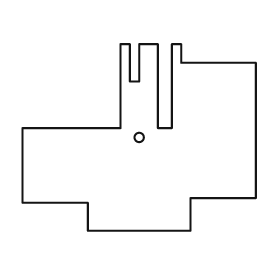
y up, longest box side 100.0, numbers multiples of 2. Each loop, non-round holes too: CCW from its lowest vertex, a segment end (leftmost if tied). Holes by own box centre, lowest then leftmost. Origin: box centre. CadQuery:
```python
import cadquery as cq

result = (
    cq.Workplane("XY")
    .moveTo(-22.0, -40.0)
    .lineTo(22.0, -40.0)
    .lineTo(22.0, -26.0)
    .lineTo(50.0, -26.0)
    .lineTo(50.0, 32.0)
    .lineTo(18.0, 32.0)
    .lineTo(18.0, 40.0)
    .lineTo(14.0, 40.0)
    .lineTo(14.0, 4.0)
    .lineTo(8.0, 4.0)
    .lineTo(8.0, 40.0)
    .lineTo(0.0, 40.0)
    .lineTo(0.0, 24.0)
    .lineTo(-4.0, 24.0)
    .lineTo(-4.0, 40.0)
    .lineTo(-8.0, 40.0)
    .lineTo(-8.0, 4.0)
    .lineTo(-50.0, 4.0)
    .lineTo(-50.0, -28.0)
    .lineTo(-22.0, -28.0)
    .close()
    .moveTo(0.0, 0.0)
    .circle(2.0)
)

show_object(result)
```